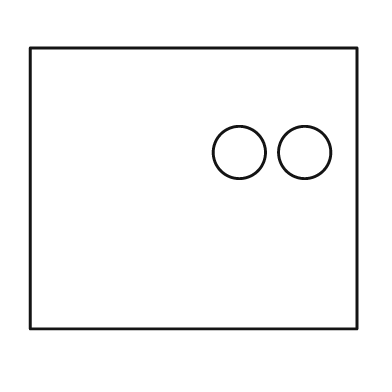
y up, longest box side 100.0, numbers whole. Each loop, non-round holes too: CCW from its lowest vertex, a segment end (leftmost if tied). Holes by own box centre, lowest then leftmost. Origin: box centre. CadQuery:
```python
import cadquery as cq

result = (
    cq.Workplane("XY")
    .moveTo(-50.0, -43.0)
    .lineTo(50.0, -43.0)
    .lineTo(50.0, 43.0)
    .lineTo(-50.0, 43.0)
    .close()
    .moveTo(14.0, 11.0)
    .circle(8.0)
    .moveTo(34.0, 11.0)
    .circle(8.0)
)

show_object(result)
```